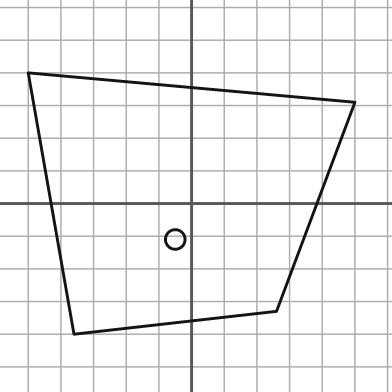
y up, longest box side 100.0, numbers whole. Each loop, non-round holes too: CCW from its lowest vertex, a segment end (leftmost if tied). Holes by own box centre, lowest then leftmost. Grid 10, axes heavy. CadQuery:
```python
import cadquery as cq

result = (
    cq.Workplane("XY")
    .moveTo(-36.0, -40.0)
    .lineTo(26.0, -33.0)
    .lineTo(50.0, 31.0)
    .lineTo(-50.0, 40.0)
    .close()
    .moveTo(-5.0, -11.0)
    .circle(3.0)
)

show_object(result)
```